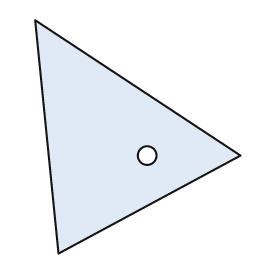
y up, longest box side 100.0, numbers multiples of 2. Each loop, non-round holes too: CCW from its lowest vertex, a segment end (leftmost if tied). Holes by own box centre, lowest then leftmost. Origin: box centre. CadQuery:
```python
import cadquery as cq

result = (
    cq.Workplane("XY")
    .moveTo(-34.0, -50.0)
    .lineTo(44.0, -8.0)
    .lineTo(-44.0, 50.0)
    .close()
    .moveTo(4.0, -8.0)
    .circle(4.0)
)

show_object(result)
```